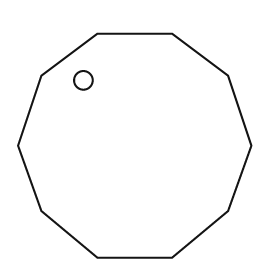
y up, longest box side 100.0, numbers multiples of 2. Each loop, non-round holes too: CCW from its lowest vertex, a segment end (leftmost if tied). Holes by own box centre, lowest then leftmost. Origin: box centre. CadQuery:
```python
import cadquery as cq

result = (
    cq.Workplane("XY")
    .moveTo(-16.0, -48.0)
    .lineTo(16.0, -48.0)
    .lineTo(40.0, -28.0)
    .lineTo(50.0, 0.0)
    .lineTo(40.0, 30.0)
    .lineTo(16.0, 48.0)
    .lineTo(-16.0, 48.0)
    .lineTo(-40.0, 30.0)
    .lineTo(-50.0, 0.0)
    .lineTo(-40.0, -28.0)
    .close()
    .moveTo(-22.0, 28.0)
    .circle(4.0)
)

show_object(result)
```